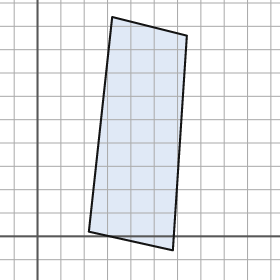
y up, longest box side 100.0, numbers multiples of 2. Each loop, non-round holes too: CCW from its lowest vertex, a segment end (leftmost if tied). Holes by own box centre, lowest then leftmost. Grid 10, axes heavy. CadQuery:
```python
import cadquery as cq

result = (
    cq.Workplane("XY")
    .moveTo(58.0, -6.0)
    .lineTo(64.0, 86.0)
    .lineTo(32.0, 94.0)
    .lineTo(22.0, 2.0)
    .close()
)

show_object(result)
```